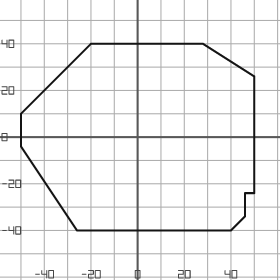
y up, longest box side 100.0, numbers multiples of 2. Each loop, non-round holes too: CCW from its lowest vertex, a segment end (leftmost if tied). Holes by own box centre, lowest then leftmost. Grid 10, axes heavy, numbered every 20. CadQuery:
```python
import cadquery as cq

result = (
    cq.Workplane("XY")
    .moveTo(-26.0, -40.0)
    .lineTo(40.0, -40.0)
    .lineTo(46.0, -34.0)
    .lineTo(46.0, -24.0)
    .lineTo(50.0, -24.0)
    .lineTo(50.0, 26.0)
    .lineTo(28.0, 40.0)
    .lineTo(-20.0, 40.0)
    .lineTo(-50.0, 10.0)
    .lineTo(-50.0, -4.0)
    .close()
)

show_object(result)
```